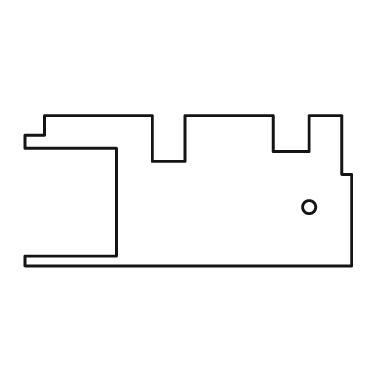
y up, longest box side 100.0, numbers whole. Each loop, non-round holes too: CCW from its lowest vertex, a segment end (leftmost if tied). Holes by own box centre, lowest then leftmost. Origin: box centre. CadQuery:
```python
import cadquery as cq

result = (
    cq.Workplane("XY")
    .moveTo(-50.0, -23.0)
    .lineTo(50.0, -23.0)
    .lineTo(50.0, 5.0)
    .lineTo(47.0, 5.0)
    .lineTo(47.0, 23.0)
    .lineTo(37.0, 23.0)
    .lineTo(37.0, 12.0)
    .lineTo(26.0, 12.0)
    .lineTo(26.0, 23.0)
    .lineTo(-1.0, 23.0)
    .lineTo(-1.0, 9.0)
    .lineTo(-11.0, 9.0)
    .lineTo(-11.0, 23.0)
    .lineTo(-44.0, 23.0)
    .lineTo(-44.0, 17.0)
    .lineTo(-50.0, 17.0)
    .lineTo(-50.0, 13.0)
    .lineTo(-22.0, 13.0)
    .lineTo(-22.0, -20.0)
    .lineTo(-50.0, -20.0)
    .close()
    .moveTo(37.0, -5.0)
    .circle(2.0)
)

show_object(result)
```